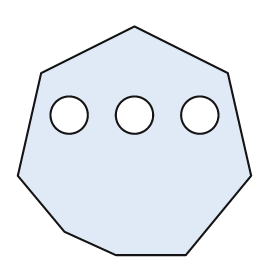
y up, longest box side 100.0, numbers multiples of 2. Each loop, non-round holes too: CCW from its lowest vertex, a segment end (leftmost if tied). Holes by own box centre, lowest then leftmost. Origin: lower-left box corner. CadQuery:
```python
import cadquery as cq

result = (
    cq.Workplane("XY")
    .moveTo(42.0, 0.0)
    .lineTo(72.0, 0.0)
    .lineTo(100.0, 34.0)
    .lineTo(90.0, 78.0)
    .lineTo(50.0, 98.0)
    .lineTo(10.0, 78.0)
    .lineTo(0.0, 34.0)
    .lineTo(20.0, 10.0)
    .close()
    .moveTo(22.0, 60.0)
    .circle(8.0)
    .moveTo(50.0, 60.0)
    .circle(8.0)
    .moveTo(78.0, 60.0)
    .circle(8.0)
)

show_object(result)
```